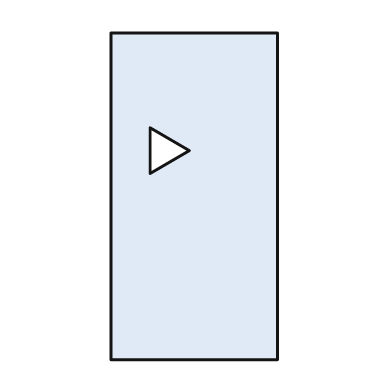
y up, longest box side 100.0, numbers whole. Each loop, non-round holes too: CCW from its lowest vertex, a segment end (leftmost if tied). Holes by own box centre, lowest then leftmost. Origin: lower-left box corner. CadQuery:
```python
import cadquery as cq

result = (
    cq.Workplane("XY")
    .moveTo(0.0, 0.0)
    .lineTo(51.0, 0.0)
    .lineTo(51.0, 100.0)
    .lineTo(0.0, 100.0)
    .close()
    .moveTo(12.0, 57.0)
    .lineTo(24.0, 64.0)
    .lineTo(12.0, 71.0)
    .close()
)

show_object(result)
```